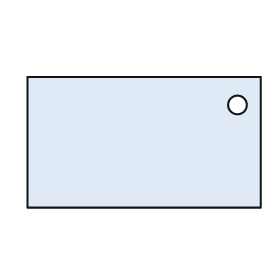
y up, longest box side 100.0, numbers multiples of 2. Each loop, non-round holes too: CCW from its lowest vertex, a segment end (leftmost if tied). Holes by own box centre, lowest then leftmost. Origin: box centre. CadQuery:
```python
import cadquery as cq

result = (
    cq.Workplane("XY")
    .moveTo(-50.0, -28.0)
    .lineTo(50.0, -28.0)
    .lineTo(50.0, 28.0)
    .lineTo(-50.0, 28.0)
    .close()
    .moveTo(40.0, 16.0)
    .circle(4.0)
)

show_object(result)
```